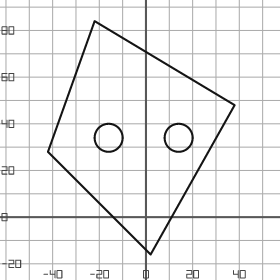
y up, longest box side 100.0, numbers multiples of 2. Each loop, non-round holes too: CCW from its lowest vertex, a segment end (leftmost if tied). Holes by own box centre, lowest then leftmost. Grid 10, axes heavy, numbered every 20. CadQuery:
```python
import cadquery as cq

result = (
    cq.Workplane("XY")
    .moveTo(2.0, -16.0)
    .lineTo(38.0, 48.0)
    .lineTo(-22.0, 84.0)
    .lineTo(-42.0, 28.0)
    .close()
    .moveTo(-16.0, 34.0)
    .circle(6.0)
    .moveTo(14.0, 34.0)
    .circle(6.0)
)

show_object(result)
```